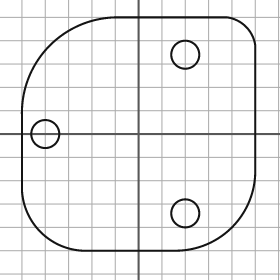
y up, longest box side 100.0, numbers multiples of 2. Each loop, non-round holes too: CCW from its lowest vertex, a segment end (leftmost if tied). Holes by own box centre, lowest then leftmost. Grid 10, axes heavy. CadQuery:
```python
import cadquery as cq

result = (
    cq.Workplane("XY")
    .moveTo(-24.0, -50.0)
    .lineTo(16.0, -50.0)
    .threePointArc((40.0, -40.0), (50.0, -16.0))
    .lineTo(50.0, 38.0)
    .threePointArc((46.0, 46.0), (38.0, 50.0))
    .lineTo(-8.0, 50.0)
    .threePointArc((-38.0, 38.0), (-50.0, 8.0))
    .lineTo(-50.0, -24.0)
    .threePointArc((-42.0, -42.0), (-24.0, -50.0))
    .close()
    .moveTo(20.0, -34.0)
    .circle(6.0)
    .moveTo(-40.0, 0.0)
    .circle(6.0)
    .moveTo(20.0, 34.0)
    .circle(6.0)
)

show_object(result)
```